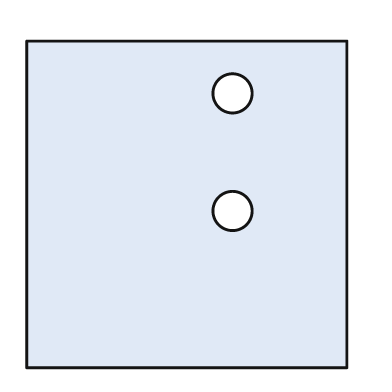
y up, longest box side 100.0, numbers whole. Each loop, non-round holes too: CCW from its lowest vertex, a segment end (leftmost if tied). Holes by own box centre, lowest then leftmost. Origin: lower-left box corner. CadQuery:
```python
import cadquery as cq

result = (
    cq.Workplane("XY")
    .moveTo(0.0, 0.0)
    .lineTo(98.0, 0.0)
    .lineTo(98.0, 100.0)
    .lineTo(0.0, 100.0)
    .close()
    .moveTo(63.0, 48.0)
    .circle(6.0)
    .moveTo(63.0, 84.0)
    .circle(6.0)
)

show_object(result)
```